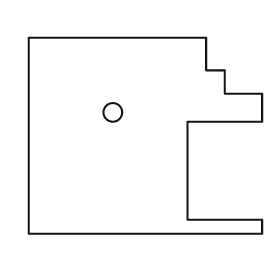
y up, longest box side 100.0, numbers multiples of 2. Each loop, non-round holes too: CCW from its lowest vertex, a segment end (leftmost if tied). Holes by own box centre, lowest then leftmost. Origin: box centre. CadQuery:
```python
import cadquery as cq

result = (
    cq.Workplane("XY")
    .moveTo(-50.0, -42.0)
    .lineTo(50.0, -42.0)
    .lineTo(50.0, -36.0)
    .lineTo(18.0, -36.0)
    .lineTo(18.0, 6.0)
    .lineTo(50.0, 6.0)
    .lineTo(50.0, 18.0)
    .lineTo(34.0, 18.0)
    .lineTo(34.0, 28.0)
    .lineTo(26.0, 28.0)
    .lineTo(26.0, 42.0)
    .lineTo(-50.0, 42.0)
    .close()
    .moveTo(-14.0, 10.0)
    .circle(4.0)
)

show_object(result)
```